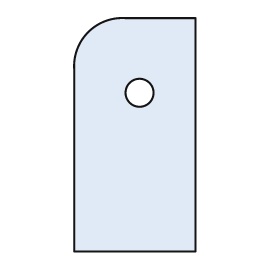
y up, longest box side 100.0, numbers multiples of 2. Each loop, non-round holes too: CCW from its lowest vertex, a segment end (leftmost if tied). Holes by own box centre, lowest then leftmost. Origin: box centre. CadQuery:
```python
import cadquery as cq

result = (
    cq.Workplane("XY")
    .moveTo(-26.0, -50.0)
    .lineTo(26.0, -50.0)
    .lineTo(26.0, 50.0)
    .lineTo(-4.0, 50.0)
    .threePointArc((-20.0, 44.0), (-26.0, 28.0))
    .close()
    .moveTo(2.0, 18.0)
    .circle(6.0)
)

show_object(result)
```